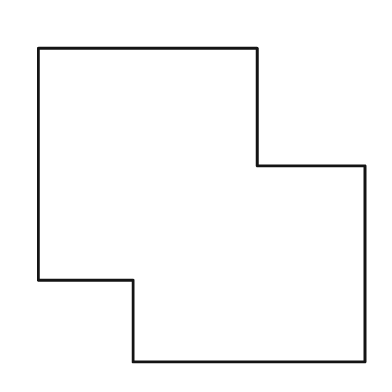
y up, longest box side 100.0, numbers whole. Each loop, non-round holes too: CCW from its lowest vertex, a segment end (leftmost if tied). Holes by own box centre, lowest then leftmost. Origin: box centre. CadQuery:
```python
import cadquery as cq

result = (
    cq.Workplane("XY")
    .moveTo(-21.0, -48.0)
    .lineTo(50.0, -48.0)
    .lineTo(50.0, 12.0)
    .lineTo(17.0, 12.0)
    .lineTo(17.0, 48.0)
    .lineTo(-50.0, 48.0)
    .lineTo(-50.0, -23.0)
    .lineTo(-21.0, -23.0)
    .close()
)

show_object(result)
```